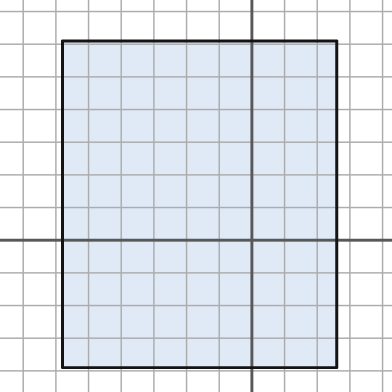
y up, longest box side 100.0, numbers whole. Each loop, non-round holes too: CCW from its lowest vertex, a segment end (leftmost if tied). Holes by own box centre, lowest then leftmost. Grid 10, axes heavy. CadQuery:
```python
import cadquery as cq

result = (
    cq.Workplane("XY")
    .moveTo(-58.0, -39.0)
    .lineTo(26.0, -39.0)
    .lineTo(26.0, 61.0)
    .lineTo(-58.0, 61.0)
    .close()
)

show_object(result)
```